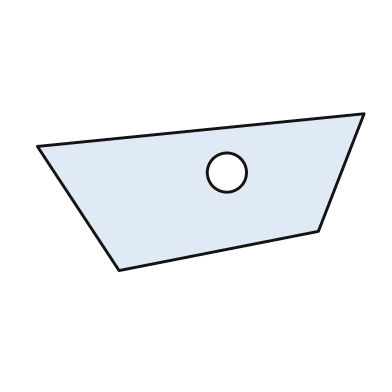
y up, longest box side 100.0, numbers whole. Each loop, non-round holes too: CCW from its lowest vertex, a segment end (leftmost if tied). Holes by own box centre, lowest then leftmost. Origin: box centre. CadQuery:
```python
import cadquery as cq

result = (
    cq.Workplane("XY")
    .moveTo(-25.0, -24.0)
    .lineTo(36.0, -12.0)
    .lineTo(50.0, 24.0)
    .lineTo(-50.0, 14.0)
    .close()
    .moveTo(8.0, 6.0)
    .circle(6.0)
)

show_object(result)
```